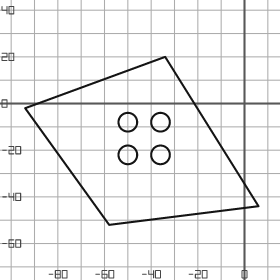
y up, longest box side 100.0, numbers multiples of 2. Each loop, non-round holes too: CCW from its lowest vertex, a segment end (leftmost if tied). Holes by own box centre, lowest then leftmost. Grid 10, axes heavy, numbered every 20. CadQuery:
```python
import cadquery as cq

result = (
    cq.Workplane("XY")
    .moveTo(-58.0, -52.0)
    .lineTo(6.0, -44.0)
    .lineTo(-34.0, 20.0)
    .lineTo(-94.0, -2.0)
    .close()
    .moveTo(-50.0, -22.0)
    .circle(4.0)
    .moveTo(-36.0, -22.0)
    .circle(4.0)
    .moveTo(-50.0, -8.0)
    .circle(4.0)
    .moveTo(-36.0, -8.0)
    .circle(4.0)
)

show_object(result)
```